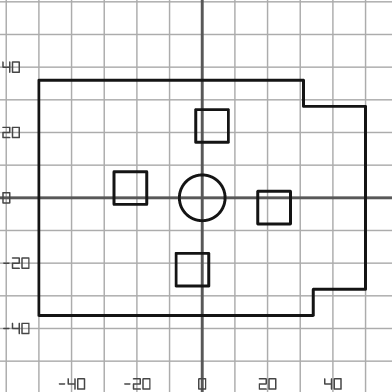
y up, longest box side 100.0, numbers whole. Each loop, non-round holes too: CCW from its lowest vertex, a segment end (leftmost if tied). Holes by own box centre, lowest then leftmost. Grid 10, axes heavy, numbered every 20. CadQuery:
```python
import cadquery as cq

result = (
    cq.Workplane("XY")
    .moveTo(-50.0, -36.0)
    .lineTo(34.0, -36.0)
    .lineTo(34.0, -28.0)
    .lineTo(50.0, -28.0)
    .lineTo(50.0, 28.0)
    .lineTo(31.0, 28.0)
    .lineTo(31.0, 36.0)
    .lineTo(-50.0, 36.0)
    .close()
    .moveTo(-8.0, -27.0)
    .lineTo(2.0, -27.0)
    .lineTo(2.0, -17.0)
    .lineTo(-8.0, -17.0)
    .close()
    .moveTo(17.0, -8.0)
    .lineTo(27.0, -8.0)
    .lineTo(27.0, 2.0)
    .lineTo(17.0, 2.0)
    .close()
    .moveTo(0.0, 0.0)
    .circle(7.0)
    .moveTo(-27.0, -2.0)
    .lineTo(-17.0, -2.0)
    .lineTo(-17.0, 8.0)
    .lineTo(-27.0, 8.0)
    .close()
    .moveTo(-2.0, 17.0)
    .lineTo(8.0, 17.0)
    .lineTo(8.0, 27.0)
    .lineTo(-2.0, 27.0)
    .close()
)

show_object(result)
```